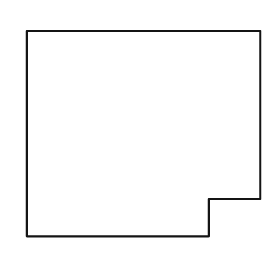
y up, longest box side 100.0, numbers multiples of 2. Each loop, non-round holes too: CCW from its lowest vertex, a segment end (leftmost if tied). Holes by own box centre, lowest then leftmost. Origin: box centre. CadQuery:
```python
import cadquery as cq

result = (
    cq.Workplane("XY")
    .moveTo(-50.0, -44.0)
    .lineTo(28.0, -44.0)
    .lineTo(28.0, -28.0)
    .lineTo(50.0, -28.0)
    .lineTo(50.0, 44.0)
    .lineTo(-50.0, 44.0)
    .close()
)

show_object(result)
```